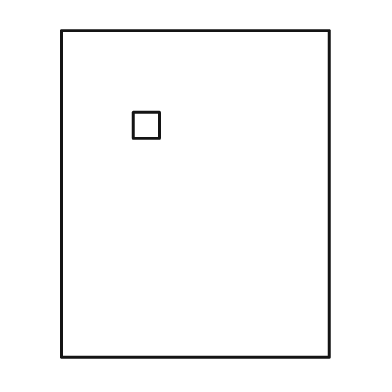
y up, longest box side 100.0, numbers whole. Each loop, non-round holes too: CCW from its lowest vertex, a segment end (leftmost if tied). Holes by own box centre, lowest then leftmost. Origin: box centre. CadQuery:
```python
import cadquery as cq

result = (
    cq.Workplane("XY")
    .moveTo(-41.0, -50.0)
    .lineTo(41.0, -50.0)
    .lineTo(41.0, 50.0)
    .lineTo(-41.0, 50.0)
    .close()
    .moveTo(-19.0, 17.0)
    .lineTo(-11.0, 17.0)
    .lineTo(-11.0, 25.0)
    .lineTo(-19.0, 25.0)
    .close()
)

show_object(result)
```